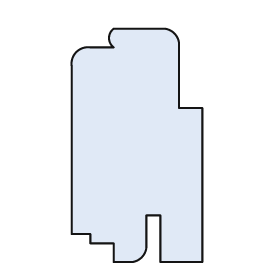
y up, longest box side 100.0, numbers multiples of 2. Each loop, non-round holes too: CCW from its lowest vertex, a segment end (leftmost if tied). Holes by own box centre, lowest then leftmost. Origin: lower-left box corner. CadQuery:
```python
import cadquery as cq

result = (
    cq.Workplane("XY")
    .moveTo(18.0, 0.0)
    .lineTo(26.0, 0.0)
    .threePointArc((30.0, 2.0), (32.0, 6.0))
    .lineTo(32.0, 20.0)
    .lineTo(38.0, 20.0)
    .lineTo(38.0, 0.0)
    .lineTo(56.0, 0.0)
    .lineTo(56.0, 66.0)
    .lineTo(46.0, 66.0)
    .lineTo(46.0, 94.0)
    .threePointArc((44.0, 98.0), (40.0, 100.0))
    .lineTo(18.0, 100.0)
    .threePointArc((16.0, 96.0), (18.0, 92.0))
    .lineTo(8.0, 92.0)
    .threePointArc((2.0, 90.0), (0.0, 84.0))
    .lineTo(0.0, 12.0)
    .lineTo(8.0, 12.0)
    .lineTo(8.0, 8.0)
    .lineTo(18.0, 8.0)
    .close()
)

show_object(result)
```